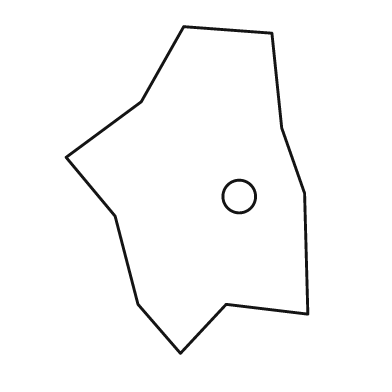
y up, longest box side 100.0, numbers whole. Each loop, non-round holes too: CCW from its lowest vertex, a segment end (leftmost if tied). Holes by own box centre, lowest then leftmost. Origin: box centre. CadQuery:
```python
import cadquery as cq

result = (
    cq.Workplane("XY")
    .moveTo(-2.0, -50.0)
    .lineTo(12.0, -35.0)
    .lineTo(37.0, -38.0)
    .lineTo(36.0, -1.0)
    .lineTo(29.0, 19.0)
    .lineTo(26.0, 48.0)
    .lineTo(-1.0, 50.0)
    .lineTo(-14.0, 27.0)
    .lineTo(-37.0, 10.0)
    .lineTo(-22.0, -8.0)
    .lineTo(-15.0, -35.0)
    .close()
    .moveTo(16.0, -2.0)
    .circle(5.0)
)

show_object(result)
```